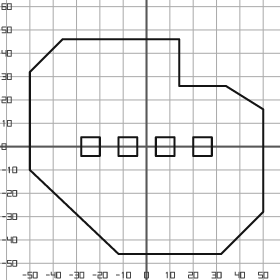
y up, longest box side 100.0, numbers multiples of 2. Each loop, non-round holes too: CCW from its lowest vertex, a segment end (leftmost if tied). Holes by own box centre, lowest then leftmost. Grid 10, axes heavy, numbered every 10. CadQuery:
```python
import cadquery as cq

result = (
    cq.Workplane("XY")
    .moveTo(-12.0, -46.0)
    .lineTo(32.0, -46.0)
    .lineTo(50.0, -28.0)
    .lineTo(50.0, 16.0)
    .lineTo(34.0, 26.0)
    .lineTo(14.0, 26.0)
    .lineTo(14.0, 46.0)
    .lineTo(-36.0, 46.0)
    .lineTo(-50.0, 32.0)
    .lineTo(-50.0, -10.0)
    .close()
    .moveTo(-28.0, -4.0)
    .lineTo(-20.0, -4.0)
    .lineTo(-20.0, 4.0)
    .lineTo(-28.0, 4.0)
    .close()
    .moveTo(-12.0, -4.0)
    .lineTo(-4.0, -4.0)
    .lineTo(-4.0, 4.0)
    .lineTo(-12.0, 4.0)
    .close()
    .moveTo(4.0, -4.0)
    .lineTo(12.0, -4.0)
    .lineTo(12.0, 4.0)
    .lineTo(4.0, 4.0)
    .close()
    .moveTo(20.0, -4.0)
    .lineTo(28.0, -4.0)
    .lineTo(28.0, 4.0)
    .lineTo(20.0, 4.0)
    .close()
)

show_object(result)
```